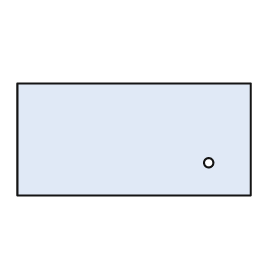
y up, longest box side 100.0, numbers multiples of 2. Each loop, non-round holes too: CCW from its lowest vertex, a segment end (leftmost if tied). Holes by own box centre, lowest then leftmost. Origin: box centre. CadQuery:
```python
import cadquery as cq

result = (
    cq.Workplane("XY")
    .moveTo(-50.0, -24.0)
    .lineTo(50.0, -24.0)
    .lineTo(50.0, 24.0)
    .lineTo(-50.0, 24.0)
    .close()
    .moveTo(32.0, -10.0)
    .circle(2.0)
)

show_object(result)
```